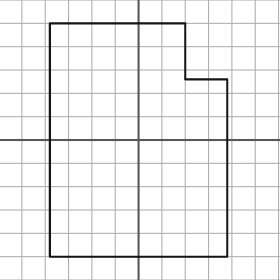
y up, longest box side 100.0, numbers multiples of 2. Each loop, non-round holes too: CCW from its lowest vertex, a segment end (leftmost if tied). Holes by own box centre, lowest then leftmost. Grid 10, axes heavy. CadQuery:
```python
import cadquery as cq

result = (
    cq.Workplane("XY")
    .moveTo(-38.0, -50.0)
    .lineTo(38.0, -50.0)
    .lineTo(38.0, 26.0)
    .lineTo(20.0, 26.0)
    .lineTo(20.0, 50.0)
    .lineTo(-38.0, 50.0)
    .close()
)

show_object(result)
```